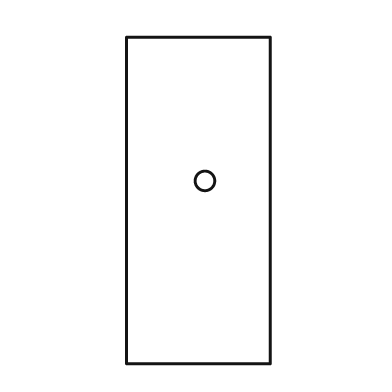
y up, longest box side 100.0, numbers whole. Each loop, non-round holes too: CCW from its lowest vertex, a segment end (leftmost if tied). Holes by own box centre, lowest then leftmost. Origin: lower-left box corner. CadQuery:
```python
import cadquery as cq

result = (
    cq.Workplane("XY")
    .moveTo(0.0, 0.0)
    .lineTo(44.0, 0.0)
    .lineTo(44.0, 100.0)
    .lineTo(0.0, 100.0)
    .close()
    .moveTo(24.0, 56.0)
    .circle(3.0)
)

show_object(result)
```